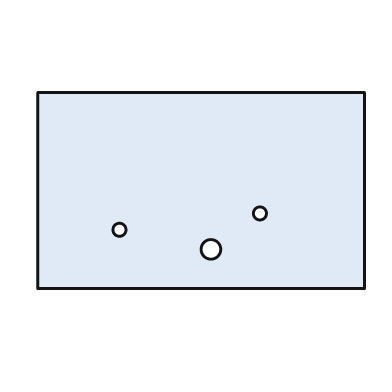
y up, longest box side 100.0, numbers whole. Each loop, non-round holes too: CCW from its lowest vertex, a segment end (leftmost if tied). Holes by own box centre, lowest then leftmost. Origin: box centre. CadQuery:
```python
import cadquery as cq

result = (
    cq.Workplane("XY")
    .moveTo(-50.0, -30.0)
    .lineTo(50.0, -30.0)
    .lineTo(50.0, 30.0)
    .lineTo(-50.0, 30.0)
    .close()
    .moveTo(3.0, -18.0)
    .circle(3.0)
    .moveTo(-25.0, -12.0)
    .circle(2.0)
    .moveTo(18.0, -7.0)
    .circle(2.0)
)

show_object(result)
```